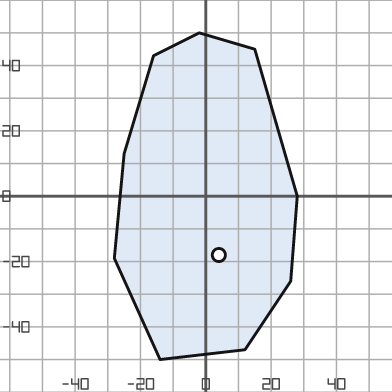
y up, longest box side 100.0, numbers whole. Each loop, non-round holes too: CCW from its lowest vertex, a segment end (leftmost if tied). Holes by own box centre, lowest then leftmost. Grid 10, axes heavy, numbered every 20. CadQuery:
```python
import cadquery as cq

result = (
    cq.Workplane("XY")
    .moveTo(-14.0, -50.0)
    .lineTo(12.0, -47.0)
    .lineTo(26.0, -26.0)
    .lineTo(28.0, 0.0)
    .lineTo(15.0, 45.0)
    .lineTo(-2.0, 50.0)
    .lineTo(-16.0, 43.0)
    .lineTo(-25.0, 13.0)
    .lineTo(-28.0, -19.0)
    .close()
    .moveTo(4.0, -18.0)
    .circle(2.0)
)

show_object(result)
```